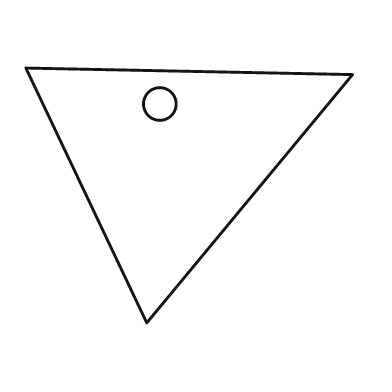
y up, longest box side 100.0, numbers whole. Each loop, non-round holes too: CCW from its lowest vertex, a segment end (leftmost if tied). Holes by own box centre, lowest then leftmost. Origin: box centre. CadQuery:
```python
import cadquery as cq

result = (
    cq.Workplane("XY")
    .moveTo(-13.0, -39.0)
    .lineTo(50.0, 37.0)
    .lineTo(-50.0, 39.0)
    .close()
    .moveTo(-9.0, 28.0)
    .circle(5.0)
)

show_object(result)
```